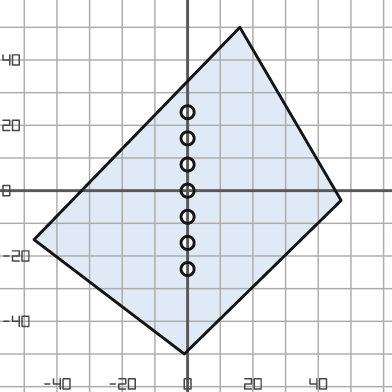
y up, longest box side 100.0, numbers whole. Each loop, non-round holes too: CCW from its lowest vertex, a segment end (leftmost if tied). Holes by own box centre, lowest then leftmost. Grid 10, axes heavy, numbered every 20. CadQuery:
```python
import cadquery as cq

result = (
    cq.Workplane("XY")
    .moveTo(-1.0, -50.0)
    .lineTo(47.0, -3.0)
    .lineTo(16.0, 50.0)
    .lineTo(-47.0, -15.0)
    .close()
    .moveTo(0.0, -24.0)
    .circle(2.0)
    .moveTo(0.0, -16.0)
    .circle(2.0)
    .moveTo(0.0, -8.0)
    .circle(2.0)
    .moveTo(0.0, 0.0)
    .circle(2.0)
    .moveTo(0.0, 8.0)
    .circle(2.0)
    .moveTo(0.0, 16.0)
    .circle(2.0)
    .moveTo(0.0, 24.0)
    .circle(2.0)
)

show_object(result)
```